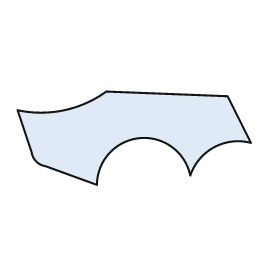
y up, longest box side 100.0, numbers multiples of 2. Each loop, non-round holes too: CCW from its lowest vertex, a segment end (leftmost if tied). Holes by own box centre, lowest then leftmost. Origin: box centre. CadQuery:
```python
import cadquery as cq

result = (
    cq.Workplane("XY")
    .moveTo(-16.0, -20.0)
    .threePointArc((2.0, 0.0), (24.0, -16.0))
    .threePointArc((34.0, -4.0), (50.0, -2.0))
    .lineTo(40.0, 18.0)
    .lineTo(-12.0, 20.0)
    .threePointArc((-30.0, 12.0), (-50.0, 12.0))
    .lineTo(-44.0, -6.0)
    .threePointArc((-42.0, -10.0), (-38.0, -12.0))
    .close()
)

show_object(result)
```